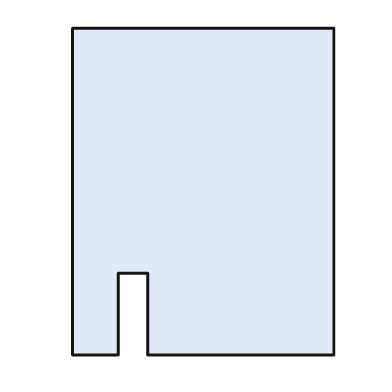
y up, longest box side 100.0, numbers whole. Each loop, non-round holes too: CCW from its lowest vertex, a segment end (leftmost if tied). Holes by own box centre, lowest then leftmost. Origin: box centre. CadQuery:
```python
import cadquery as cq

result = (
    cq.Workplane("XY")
    .moveTo(-40.0, -50.0)
    .lineTo(-26.0, -50.0)
    .lineTo(-26.0, -25.0)
    .lineTo(-17.0, -25.0)
    .lineTo(-17.0, -50.0)
    .lineTo(40.0, -50.0)
    .lineTo(40.0, 50.0)
    .lineTo(-40.0, 50.0)
    .close()
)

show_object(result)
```